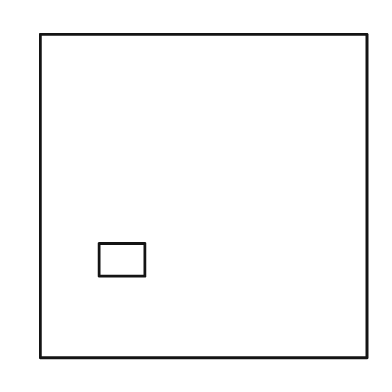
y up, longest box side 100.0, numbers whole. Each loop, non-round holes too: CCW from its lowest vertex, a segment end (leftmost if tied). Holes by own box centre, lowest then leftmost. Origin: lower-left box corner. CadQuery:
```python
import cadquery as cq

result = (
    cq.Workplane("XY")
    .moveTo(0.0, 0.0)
    .lineTo(100.0, 0.0)
    .lineTo(100.0, 99.0)
    .lineTo(0.0, 99.0)
    .close()
    .moveTo(18.0, 25.0)
    .lineTo(32.0, 25.0)
    .lineTo(32.0, 35.0)
    .lineTo(18.0, 35.0)
    .close()
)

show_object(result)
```